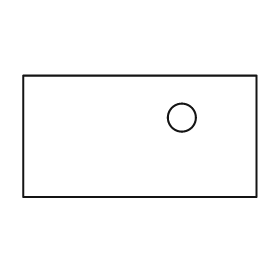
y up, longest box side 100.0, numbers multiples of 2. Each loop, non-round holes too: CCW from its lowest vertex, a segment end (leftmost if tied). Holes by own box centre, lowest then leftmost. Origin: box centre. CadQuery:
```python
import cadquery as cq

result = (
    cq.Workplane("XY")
    .moveTo(-50.0, -26.0)
    .lineTo(50.0, -26.0)
    .lineTo(50.0, 26.0)
    .lineTo(-50.0, 26.0)
    .close()
    .moveTo(18.0, 8.0)
    .circle(6.0)
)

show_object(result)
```